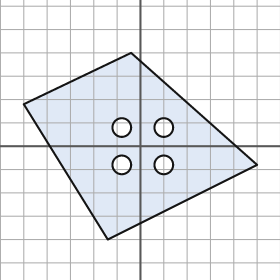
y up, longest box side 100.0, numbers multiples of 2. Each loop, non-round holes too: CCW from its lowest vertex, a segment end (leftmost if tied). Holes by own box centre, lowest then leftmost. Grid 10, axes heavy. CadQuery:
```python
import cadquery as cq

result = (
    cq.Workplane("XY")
    .moveTo(-14.0, -40.0)
    .lineTo(50.0, -8.0)
    .lineTo(-4.0, 40.0)
    .lineTo(-50.0, 18.0)
    .close()
    .moveTo(-8.0, -8.0)
    .circle(4.0)
    .moveTo(10.0, -8.0)
    .circle(4.0)
    .moveTo(-8.0, 8.0)
    .circle(4.0)
    .moveTo(10.0, 8.0)
    .circle(4.0)
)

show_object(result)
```